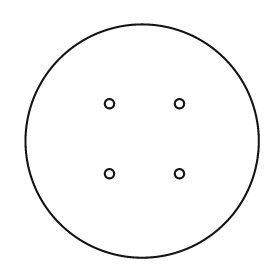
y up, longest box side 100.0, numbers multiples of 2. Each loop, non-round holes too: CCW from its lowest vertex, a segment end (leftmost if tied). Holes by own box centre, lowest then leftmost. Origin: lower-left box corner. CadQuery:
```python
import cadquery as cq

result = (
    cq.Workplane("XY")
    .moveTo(50.0, 50.0)
    .circle(50.0)
    .moveTo(36.0, 36.0)
    .circle(2.0)
    .moveTo(66.0, 36.0)
    .circle(2.0)
    .moveTo(36.0, 66.0)
    .circle(2.0)
    .moveTo(66.0, 66.0)
    .circle(2.0)
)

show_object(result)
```